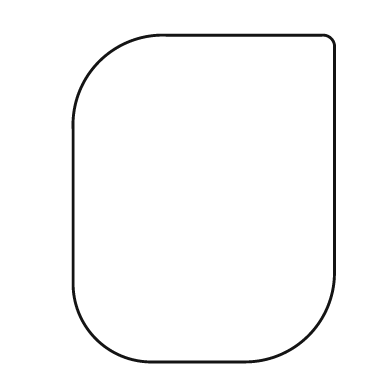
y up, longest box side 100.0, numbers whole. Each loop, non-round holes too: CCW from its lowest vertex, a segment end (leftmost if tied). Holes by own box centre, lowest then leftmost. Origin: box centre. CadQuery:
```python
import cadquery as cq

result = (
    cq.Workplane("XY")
    .moveTo(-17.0, -50.0)
    .lineTo(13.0, -50.0)
    .threePointArc((32.0, -42.0), (40.0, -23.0))
    .lineTo(40.0, 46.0)
    .threePointArc((39.0, 49.0), (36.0, 50.0))
    .lineTo(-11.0, 50.0)
    .threePointArc((-32.0, 42.0), (-40.0, 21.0))
    .lineTo(-40.0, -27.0)
    .threePointArc((-33.0, -43.0), (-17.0, -50.0))
    .close()
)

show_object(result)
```